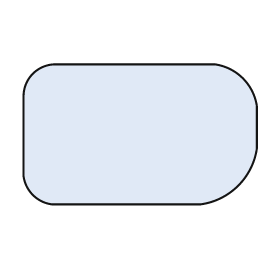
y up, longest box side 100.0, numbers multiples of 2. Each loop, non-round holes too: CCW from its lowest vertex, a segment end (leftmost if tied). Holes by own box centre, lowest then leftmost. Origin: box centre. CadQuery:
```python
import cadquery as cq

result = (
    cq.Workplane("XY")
    .moveTo(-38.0, -30.0)
    .lineTo(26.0, -30.0)
    .threePointArc((42.0, -22.0), (50.0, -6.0))
    .lineTo(50.0, 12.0)
    .threePointArc((44.0, 24.0), (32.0, 30.0))
    .lineTo(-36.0, 30.0)
    .threePointArc((-46.0, 26.0), (-50.0, 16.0))
    .lineTo(-50.0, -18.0)
    .threePointArc((-46.0, -26.0), (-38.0, -30.0))
    .close()
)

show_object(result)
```